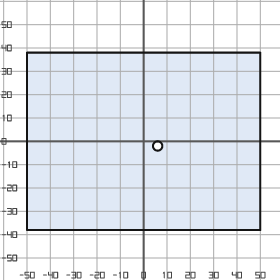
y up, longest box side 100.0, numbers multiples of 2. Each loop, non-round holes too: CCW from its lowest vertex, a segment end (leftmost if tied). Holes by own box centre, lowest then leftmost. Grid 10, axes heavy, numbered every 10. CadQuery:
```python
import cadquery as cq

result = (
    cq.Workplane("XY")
    .moveTo(-50.0, -38.0)
    .lineTo(50.0, -38.0)
    .lineTo(50.0, 38.0)
    .lineTo(-50.0, 38.0)
    .close()
    .moveTo(6.0, -2.0)
    .circle(2.0)
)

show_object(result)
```